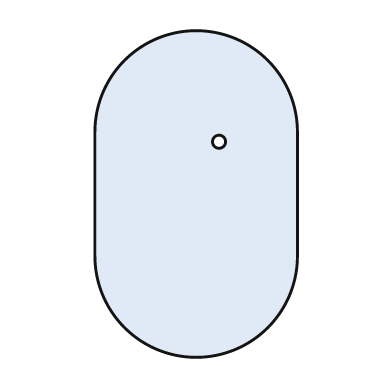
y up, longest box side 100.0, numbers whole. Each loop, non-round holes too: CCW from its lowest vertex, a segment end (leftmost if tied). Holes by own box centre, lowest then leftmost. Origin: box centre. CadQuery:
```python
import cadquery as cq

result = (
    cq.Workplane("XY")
    .moveTo(-31.0, -19.0)
    .threePointArc((0.0, -50.0), (31.0, -19.0))
    .lineTo(31.0, 19.0)
    .threePointArc((0.0, 50.0), (-31.0, 19.0))
    .close()
    .moveTo(7.0, 16.0)
    .circle(2.0)
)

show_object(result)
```